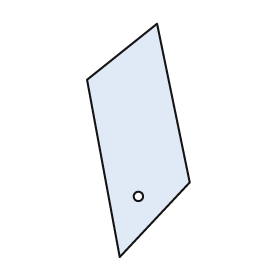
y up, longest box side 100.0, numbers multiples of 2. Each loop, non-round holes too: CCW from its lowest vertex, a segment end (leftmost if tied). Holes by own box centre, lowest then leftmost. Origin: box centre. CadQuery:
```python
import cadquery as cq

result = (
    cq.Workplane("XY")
    .moveTo(-8.0, -50.0)
    .lineTo(22.0, -18.0)
    .lineTo(8.0, 50.0)
    .lineTo(-22.0, 26.0)
    .close()
    .moveTo(0.0, -24.0)
    .circle(2.0)
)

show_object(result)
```